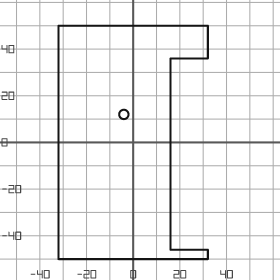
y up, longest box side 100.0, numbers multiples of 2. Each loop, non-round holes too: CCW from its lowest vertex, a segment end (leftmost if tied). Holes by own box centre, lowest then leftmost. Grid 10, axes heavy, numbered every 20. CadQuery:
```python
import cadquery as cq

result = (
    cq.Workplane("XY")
    .moveTo(-32.0, -50.0)
    .lineTo(32.0, -50.0)
    .lineTo(32.0, -46.0)
    .lineTo(16.0, -46.0)
    .lineTo(16.0, 36.0)
    .lineTo(32.0, 36.0)
    .lineTo(32.0, 50.0)
    .lineTo(-32.0, 50.0)
    .close()
    .moveTo(-4.0, 12.0)
    .circle(2.0)
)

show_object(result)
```